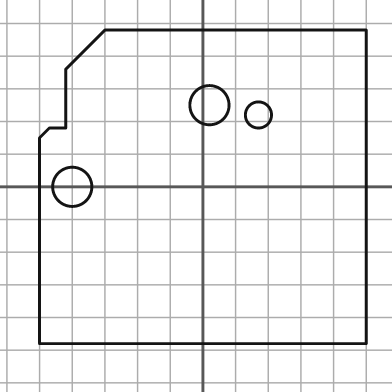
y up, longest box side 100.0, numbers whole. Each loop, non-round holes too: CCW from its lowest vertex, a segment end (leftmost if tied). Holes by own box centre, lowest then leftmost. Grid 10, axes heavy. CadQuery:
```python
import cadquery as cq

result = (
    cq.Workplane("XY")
    .moveTo(-50.0, -48.0)
    .lineTo(50.0, -48.0)
    .lineTo(50.0, 48.0)
    .lineTo(-30.0, 48.0)
    .lineTo(-42.0, 36.0)
    .lineTo(-42.0, 18.0)
    .lineTo(-47.0, 18.0)
    .lineTo(-50.0, 15.0)
    .close()
    .moveTo(-40.0, 0.0)
    .circle(6.0)
    .moveTo(17.0, 22.0)
    .circle(4.0)
    .moveTo(2.0, 25.0)
    .circle(6.0)
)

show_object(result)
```